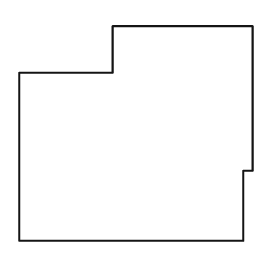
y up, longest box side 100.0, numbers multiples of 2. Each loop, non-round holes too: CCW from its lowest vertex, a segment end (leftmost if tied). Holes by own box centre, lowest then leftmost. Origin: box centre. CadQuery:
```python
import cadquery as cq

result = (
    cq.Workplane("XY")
    .moveTo(-50.0, -46.0)
    .lineTo(46.0, -46.0)
    .lineTo(46.0, -16.0)
    .lineTo(50.0, -16.0)
    .lineTo(50.0, 46.0)
    .lineTo(-10.0, 46.0)
    .lineTo(-10.0, 26.0)
    .lineTo(-50.0, 26.0)
    .close()
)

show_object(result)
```